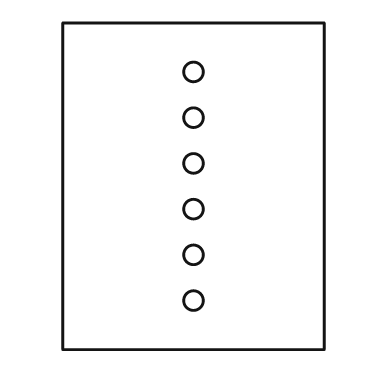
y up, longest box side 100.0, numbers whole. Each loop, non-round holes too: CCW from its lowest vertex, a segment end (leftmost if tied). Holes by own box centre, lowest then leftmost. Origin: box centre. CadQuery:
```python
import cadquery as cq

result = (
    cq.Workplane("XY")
    .moveTo(-40.0, -50.0)
    .lineTo(40.0, -50.0)
    .lineTo(40.0, 50.0)
    .lineTo(-40.0, 50.0)
    .close()
    .moveTo(0.0, -35.0)
    .circle(3.0)
    .moveTo(0.0, -21.0)
    .circle(3.0)
    .moveTo(0.0, -7.0)
    .circle(3.0)
    .moveTo(0.0, 7.0)
    .circle(3.0)
    .moveTo(0.0, 21.0)
    .circle(3.0)
    .moveTo(0.0, 35.0)
    .circle(3.0)
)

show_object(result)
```